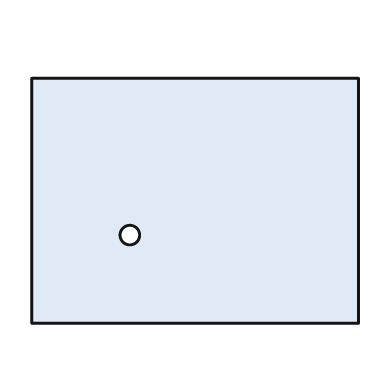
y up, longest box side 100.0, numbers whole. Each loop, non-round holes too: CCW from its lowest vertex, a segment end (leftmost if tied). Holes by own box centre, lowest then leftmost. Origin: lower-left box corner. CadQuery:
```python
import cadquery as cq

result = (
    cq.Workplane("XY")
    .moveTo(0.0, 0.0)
    .lineTo(100.0, 0.0)
    .lineTo(100.0, 75.0)
    .lineTo(0.0, 75.0)
    .close()
    .moveTo(30.0, 27.0)
    .circle(3.0)
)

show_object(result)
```